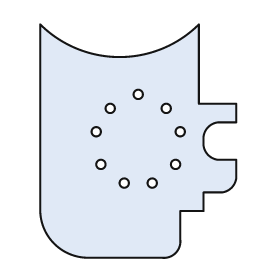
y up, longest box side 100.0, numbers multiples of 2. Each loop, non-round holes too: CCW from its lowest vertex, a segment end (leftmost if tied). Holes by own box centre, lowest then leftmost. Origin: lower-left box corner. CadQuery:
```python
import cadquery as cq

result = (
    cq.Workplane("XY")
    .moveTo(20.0, 0.0)
    .lineTo(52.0, 0.0)
    .threePointArc((58.0, 2.0), (60.0, 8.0))
    .lineTo(60.0, 20.0)
    .lineTo(70.0, 20.0)
    .lineTo(70.0, 28.0)
    .lineTo(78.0, 28.0)
    .threePointArc((82.0, 30.0), (84.0, 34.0))
    .lineTo(84.0, 42.0)
    .lineTo(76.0, 42.0)
    .threePointArc((72.0, 44.0), (70.0, 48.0))
    .lineTo(70.0, 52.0)
    .threePointArc((72.0, 56.0), (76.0, 58.0))
    .lineTo(84.0, 58.0)
    .lineTo(84.0, 66.0)
    .lineTo(68.0, 66.0)
    .lineTo(68.0, 100.0)
    .threePointArc((34.0, 86.0), (0.0, 100.0))
    .lineTo(0.0, 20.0)
    .threePointArc((6.0, 6.0), (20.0, 0.0))
    .close()
    .moveTo(36.0, 32.0)
    .circle(2.0)
    .moveTo(48.0, 32.0)
    .circle(2.0)
    .moveTo(26.0, 40.0)
    .circle(2.0)
    .moveTo(58.0, 40.0)
    .circle(2.0)
    .moveTo(24.0, 54.0)
    .circle(2.0)
    .moveTo(60.0, 54.0)
    .circle(2.0)
    .moveTo(30.0, 64.0)
    .circle(2.0)
    .moveTo(54.0, 64.0)
    .circle(2.0)
    .moveTo(42.0, 70.0)
    .circle(2.0)
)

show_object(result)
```